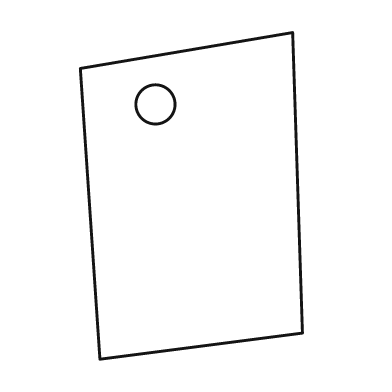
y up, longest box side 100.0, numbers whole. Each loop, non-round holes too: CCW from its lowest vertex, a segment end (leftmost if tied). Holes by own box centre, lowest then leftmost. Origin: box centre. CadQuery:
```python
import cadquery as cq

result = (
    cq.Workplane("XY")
    .moveTo(-28.0, -50.0)
    .lineTo(34.0, -42.0)
    .lineTo(31.0, 50.0)
    .lineTo(-34.0, 39.0)
    .close()
    .moveTo(-11.0, 28.0)
    .circle(6.0)
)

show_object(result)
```